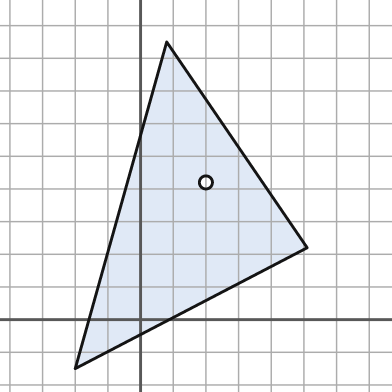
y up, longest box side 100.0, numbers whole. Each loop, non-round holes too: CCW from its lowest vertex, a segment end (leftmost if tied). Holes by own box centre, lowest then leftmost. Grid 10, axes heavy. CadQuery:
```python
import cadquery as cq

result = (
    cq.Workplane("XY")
    .moveTo(-20.0, -15.0)
    .lineTo(51.0, 22.0)
    .lineTo(8.0, 85.0)
    .close()
    .moveTo(20.0, 42.0)
    .circle(2.0)
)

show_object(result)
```